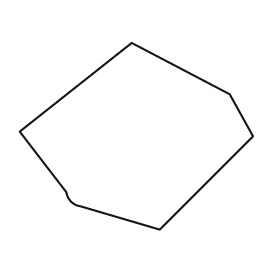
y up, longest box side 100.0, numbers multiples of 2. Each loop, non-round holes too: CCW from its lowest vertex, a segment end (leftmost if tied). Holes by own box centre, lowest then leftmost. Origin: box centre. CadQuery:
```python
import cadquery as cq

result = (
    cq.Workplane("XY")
    .moveTo(10.0, -40.0)
    .lineTo(50.0, 0.0)
    .lineTo(40.0, 18.0)
    .lineTo(-2.0, 40.0)
    .lineTo(-50.0, 2.0)
    .lineTo(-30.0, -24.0)
    .threePointArc((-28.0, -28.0), (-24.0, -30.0))
    .close()
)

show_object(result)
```